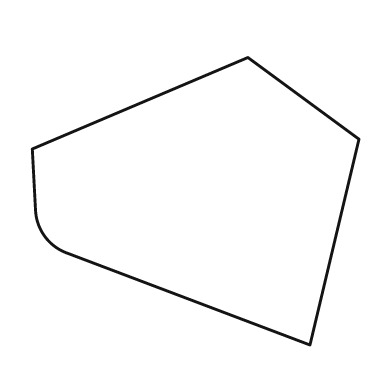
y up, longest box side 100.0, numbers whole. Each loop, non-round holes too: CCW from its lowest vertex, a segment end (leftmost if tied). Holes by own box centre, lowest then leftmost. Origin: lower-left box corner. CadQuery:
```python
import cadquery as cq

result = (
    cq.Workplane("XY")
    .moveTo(85.0, 0.0)
    .lineTo(100.0, 63.0)
    .lineTo(66.0, 88.0)
    .lineTo(0.0, 60.0)
    .lineTo(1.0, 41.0)
    .threePointArc((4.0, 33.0), (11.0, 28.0))
    .close()
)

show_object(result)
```